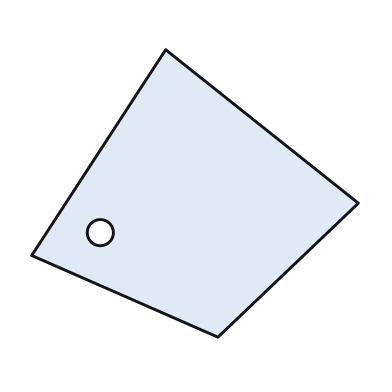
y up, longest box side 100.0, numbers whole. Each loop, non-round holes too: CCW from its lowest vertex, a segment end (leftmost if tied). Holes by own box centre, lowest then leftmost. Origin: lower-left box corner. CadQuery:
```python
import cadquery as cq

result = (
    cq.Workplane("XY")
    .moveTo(57.0, 0.0)
    .lineTo(100.0, 41.0)
    .lineTo(41.0, 88.0)
    .lineTo(0.0, 25.0)
    .close()
    .moveTo(21.0, 32.0)
    .circle(4.0)
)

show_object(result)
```